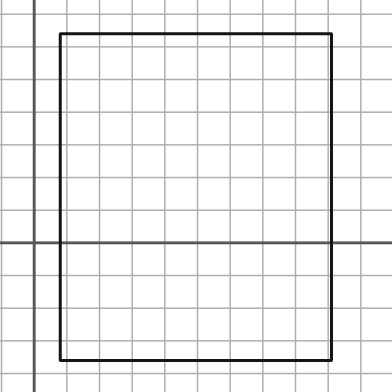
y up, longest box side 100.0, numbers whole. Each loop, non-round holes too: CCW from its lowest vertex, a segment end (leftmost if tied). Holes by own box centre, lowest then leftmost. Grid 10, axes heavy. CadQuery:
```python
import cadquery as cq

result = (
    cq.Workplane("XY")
    .moveTo(8.0, -36.0)
    .lineTo(91.0, -36.0)
    .lineTo(91.0, 64.0)
    .lineTo(8.0, 64.0)
    .close()
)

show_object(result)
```